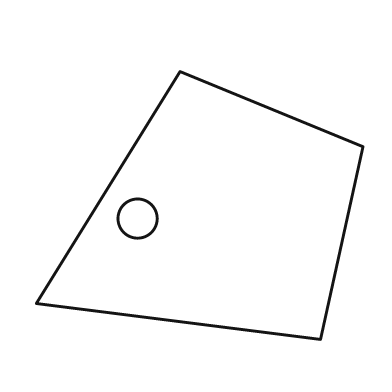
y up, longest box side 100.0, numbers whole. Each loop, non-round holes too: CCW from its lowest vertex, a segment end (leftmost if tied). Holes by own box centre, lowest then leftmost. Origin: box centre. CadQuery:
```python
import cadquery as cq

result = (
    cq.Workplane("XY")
    .moveTo(37.0, -41.0)
    .lineTo(50.0, 18.0)
    .lineTo(-6.0, 41.0)
    .lineTo(-50.0, -30.0)
    .close()
    .moveTo(-19.0, -4.0)
    .circle(6.0)
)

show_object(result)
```